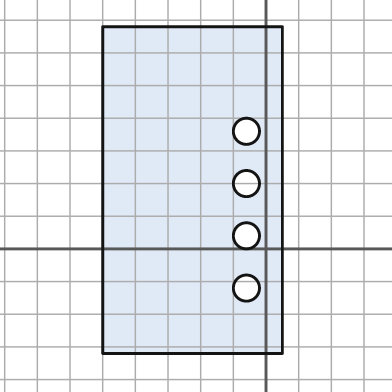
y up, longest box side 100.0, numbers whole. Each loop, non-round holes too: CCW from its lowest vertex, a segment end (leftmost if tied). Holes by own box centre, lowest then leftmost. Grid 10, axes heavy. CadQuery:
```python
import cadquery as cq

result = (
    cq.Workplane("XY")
    .moveTo(-50.0, -32.0)
    .lineTo(5.0, -32.0)
    .lineTo(5.0, 68.0)
    .lineTo(-50.0, 68.0)
    .close()
    .moveTo(-6.0, -12.0)
    .circle(4.0)
    .moveTo(-6.0, 4.0)
    .circle(4.0)
    .moveTo(-6.0, 20.0)
    .circle(4.0)
    .moveTo(-6.0, 36.0)
    .circle(4.0)
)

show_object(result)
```